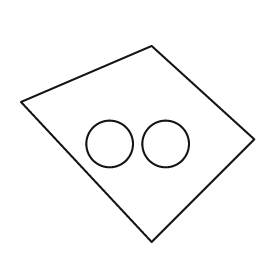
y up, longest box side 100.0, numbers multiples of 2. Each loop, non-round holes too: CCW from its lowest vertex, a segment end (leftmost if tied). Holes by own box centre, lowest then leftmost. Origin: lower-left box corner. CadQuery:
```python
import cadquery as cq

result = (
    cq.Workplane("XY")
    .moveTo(56.0, 0.0)
    .lineTo(100.0, 44.0)
    .lineTo(56.0, 84.0)
    .lineTo(0.0, 60.0)
    .close()
    .moveTo(38.0, 42.0)
    .circle(10.0)
    .moveTo(62.0, 42.0)
    .circle(10.0)
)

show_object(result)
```